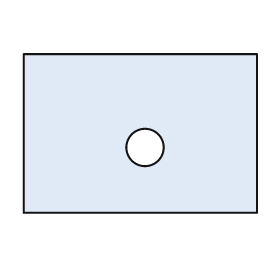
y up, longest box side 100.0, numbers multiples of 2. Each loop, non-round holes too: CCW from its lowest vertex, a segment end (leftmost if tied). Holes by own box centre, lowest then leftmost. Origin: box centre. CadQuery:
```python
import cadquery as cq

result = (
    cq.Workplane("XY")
    .moveTo(-50.0, -34.0)
    .lineTo(50.0, -34.0)
    .lineTo(50.0, 34.0)
    .lineTo(-50.0, 34.0)
    .close()
    .moveTo(2.0, -6.0)
    .circle(8.0)
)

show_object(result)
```